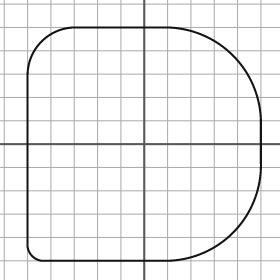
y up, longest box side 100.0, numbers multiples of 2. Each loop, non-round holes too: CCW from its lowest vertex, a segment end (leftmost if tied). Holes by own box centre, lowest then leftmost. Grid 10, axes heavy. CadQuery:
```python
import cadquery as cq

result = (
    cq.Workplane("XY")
    .moveTo(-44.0, -50.0)
    .lineTo(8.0, -50.0)
    .threePointArc((38.0, -38.0), (50.0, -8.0))
    .lineTo(50.0, 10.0)
    .threePointArc((38.0, 38.0), (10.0, 50.0))
    .lineTo(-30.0, 50.0)
    .threePointArc((-44.0, 44.0), (-50.0, 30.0))
    .lineTo(-50.0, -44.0)
    .threePointArc((-48.0, -48.0), (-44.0, -50.0))
    .close()
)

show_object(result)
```